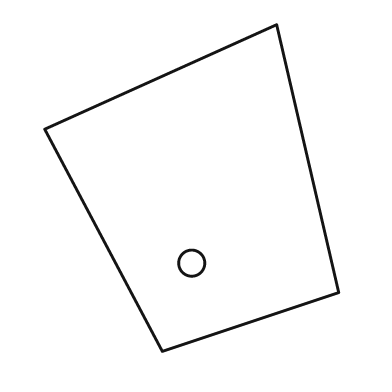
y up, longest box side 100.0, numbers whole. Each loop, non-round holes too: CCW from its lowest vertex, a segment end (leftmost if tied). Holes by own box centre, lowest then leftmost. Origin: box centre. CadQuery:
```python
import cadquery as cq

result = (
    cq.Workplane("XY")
    .moveTo(-9.0, -50.0)
    .lineTo(45.0, -32.0)
    .lineTo(26.0, 50.0)
    .lineTo(-45.0, 18.0)
    .close()
    .moveTo(0.0, -23.0)
    .circle(4.0)
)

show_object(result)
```